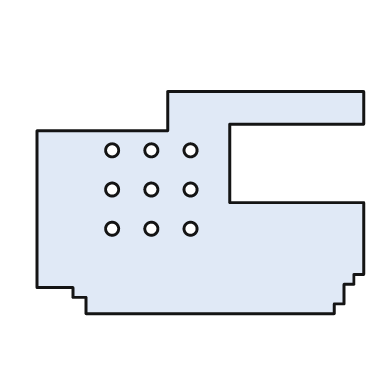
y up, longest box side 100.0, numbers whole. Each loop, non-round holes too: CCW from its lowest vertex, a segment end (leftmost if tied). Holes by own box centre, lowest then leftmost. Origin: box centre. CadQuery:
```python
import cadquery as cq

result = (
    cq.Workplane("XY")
    .moveTo(-35.0, -34.0)
    .lineTo(41.0, -34.0)
    .lineTo(41.0, -31.0)
    .lineTo(44.0, -31.0)
    .lineTo(44.0, -25.0)
    .lineTo(47.0, -25.0)
    .lineTo(47.0, -22.0)
    .lineTo(50.0, -22.0)
    .lineTo(50.0, 0.0)
    .lineTo(9.0, 0.0)
    .lineTo(9.0, 24.0)
    .lineTo(50.0, 24.0)
    .lineTo(50.0, 34.0)
    .lineTo(-10.0, 34.0)
    .lineTo(-10.0, 22.0)
    .lineTo(-50.0, 22.0)
    .lineTo(-50.0, -26.0)
    .lineTo(-39.0, -26.0)
    .lineTo(-39.0, -29.0)
    .lineTo(-35.0, -29.0)
    .close()
    .moveTo(-27.0, -8.0)
    .circle(2.0)
    .moveTo(-15.0, -8.0)
    .circle(2.0)
    .moveTo(-3.0, -8.0)
    .circle(2.0)
    .moveTo(-27.0, 4.0)
    .circle(2.0)
    .moveTo(-15.0, 4.0)
    .circle(2.0)
    .moveTo(-3.0, 4.0)
    .circle(2.0)
    .moveTo(-27.0, 16.0)
    .circle(2.0)
    .moveTo(-15.0, 16.0)
    .circle(2.0)
    .moveTo(-3.0, 16.0)
    .circle(2.0)
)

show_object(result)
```